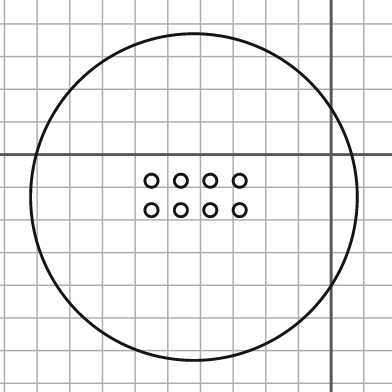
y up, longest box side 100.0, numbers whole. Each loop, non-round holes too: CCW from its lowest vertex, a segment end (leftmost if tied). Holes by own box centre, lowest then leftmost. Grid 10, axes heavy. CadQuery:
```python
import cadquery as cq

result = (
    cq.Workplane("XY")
    .moveTo(-42.0, -13.0)
    .circle(50.0)
    .moveTo(-55.0, -17.0)
    .circle(2.0)
    .moveTo(-46.0, -17.0)
    .circle(2.0)
    .moveTo(-37.0, -17.0)
    .circle(2.0)
    .moveTo(-28.0, -17.0)
    .circle(2.0)
    .moveTo(-55.0, -8.0)
    .circle(2.0)
    .moveTo(-46.0, -8.0)
    .circle(2.0)
    .moveTo(-37.0, -8.0)
    .circle(2.0)
    .moveTo(-28.0, -8.0)
    .circle(2.0)
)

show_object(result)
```